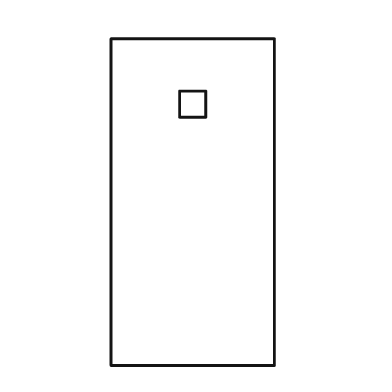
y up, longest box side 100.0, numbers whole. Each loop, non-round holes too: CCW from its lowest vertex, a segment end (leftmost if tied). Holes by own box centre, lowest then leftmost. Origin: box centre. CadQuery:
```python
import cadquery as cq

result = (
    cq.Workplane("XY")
    .moveTo(-25.0, -50.0)
    .lineTo(25.0, -50.0)
    .lineTo(25.0, 50.0)
    .lineTo(-25.0, 50.0)
    .close()
    .moveTo(-4.0, 26.0)
    .lineTo(4.0, 26.0)
    .lineTo(4.0, 34.0)
    .lineTo(-4.0, 34.0)
    .close()
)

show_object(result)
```